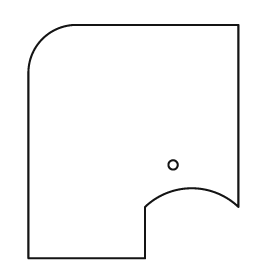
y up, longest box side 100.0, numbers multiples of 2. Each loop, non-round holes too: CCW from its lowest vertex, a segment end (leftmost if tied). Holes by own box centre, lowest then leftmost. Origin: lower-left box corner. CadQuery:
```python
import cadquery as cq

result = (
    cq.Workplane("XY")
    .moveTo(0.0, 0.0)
    .lineTo(50.0, 0.0)
    .lineTo(50.0, 22.0)
    .threePointArc((70.0, 30.0), (90.0, 22.0))
    .lineTo(90.0, 100.0)
    .lineTo(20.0, 100.0)
    .threePointArc((6.0, 94.0), (0.0, 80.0))
    .close()
    .moveTo(62.0, 40.0)
    .circle(2.0)
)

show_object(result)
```